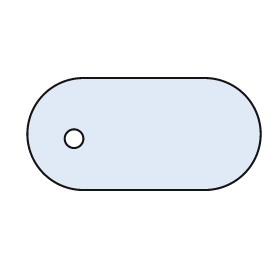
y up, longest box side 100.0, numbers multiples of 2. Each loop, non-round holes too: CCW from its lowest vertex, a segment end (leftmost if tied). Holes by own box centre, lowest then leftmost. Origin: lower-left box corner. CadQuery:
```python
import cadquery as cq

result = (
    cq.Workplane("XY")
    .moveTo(24.0, 0.0)
    .lineTo(76.0, 0.0)
    .threePointArc((100.0, 24.0), (76.0, 48.0))
    .lineTo(24.0, 48.0)
    .threePointArc((0.0, 24.0), (24.0, 0.0))
    .close()
    .moveTo(20.0, 22.0)
    .circle(4.0)
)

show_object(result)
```